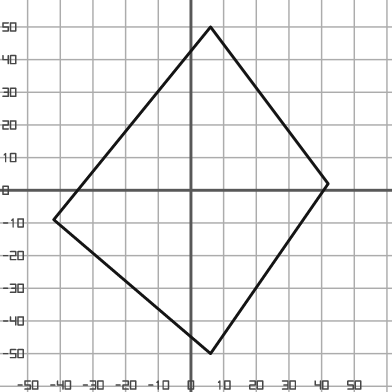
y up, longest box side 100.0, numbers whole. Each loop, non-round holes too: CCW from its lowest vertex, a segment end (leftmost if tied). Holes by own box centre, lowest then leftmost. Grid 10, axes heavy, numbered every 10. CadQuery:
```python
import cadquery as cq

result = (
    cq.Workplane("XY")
    .moveTo(6.0, -50.0)
    .lineTo(42.0, 2.0)
    .lineTo(6.0, 50.0)
    .lineTo(-42.0, -9.0)
    .close()
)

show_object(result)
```